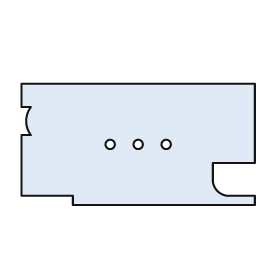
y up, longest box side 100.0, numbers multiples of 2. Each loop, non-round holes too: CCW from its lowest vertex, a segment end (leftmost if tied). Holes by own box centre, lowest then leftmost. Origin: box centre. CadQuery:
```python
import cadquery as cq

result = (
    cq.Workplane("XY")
    .moveTo(-28.0, -26.0)
    .lineTo(50.0, -26.0)
    .lineTo(50.0, -22.0)
    .lineTo(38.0, -22.0)
    .threePointArc((34.0, -20.0), (32.0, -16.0))
    .lineTo(32.0, -8.0)
    .lineTo(50.0, -8.0)
    .lineTo(50.0, 26.0)
    .lineTo(-50.0, 26.0)
    .lineTo(-50.0, 16.0)
    .lineTo(-46.0, 16.0)
    .threePointArc((-48.0, 10.0), (-46.0, 4.0))
    .lineTo(-50.0, 4.0)
    .lineTo(-50.0, -22.0)
    .lineTo(-28.0, -22.0)
    .close()
    .moveTo(-12.0, 0.0)
    .circle(2.0)
    .moveTo(0.0, 0.0)
    .circle(2.0)
    .moveTo(12.0, 0.0)
    .circle(2.0)
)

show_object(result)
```